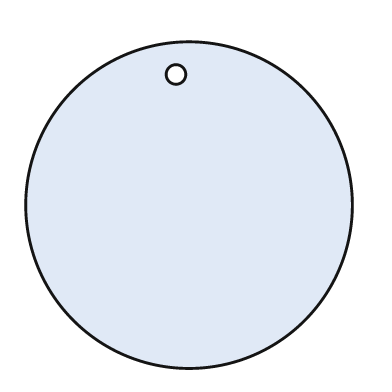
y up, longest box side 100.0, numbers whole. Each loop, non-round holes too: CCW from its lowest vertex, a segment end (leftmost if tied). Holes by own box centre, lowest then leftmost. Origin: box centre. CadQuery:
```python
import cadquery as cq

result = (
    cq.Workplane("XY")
    .moveTo(0.0, 0.0)
    .circle(50.0)
    .moveTo(-4.0, 40.0)
    .circle(3.0)
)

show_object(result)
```